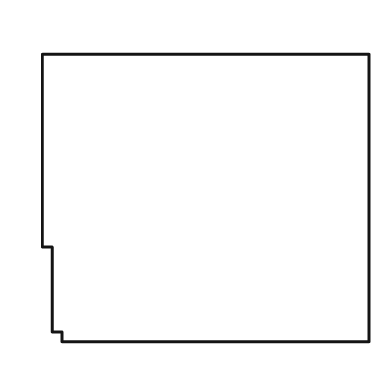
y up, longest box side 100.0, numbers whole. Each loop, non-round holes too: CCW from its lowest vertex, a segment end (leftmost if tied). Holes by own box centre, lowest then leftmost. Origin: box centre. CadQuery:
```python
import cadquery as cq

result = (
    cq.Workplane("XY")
    .moveTo(-44.0, -44.0)
    .lineTo(50.0, -44.0)
    .lineTo(50.0, 44.0)
    .lineTo(-50.0, 44.0)
    .lineTo(-50.0, -15.0)
    .lineTo(-47.0, -15.0)
    .lineTo(-47.0, -41.0)
    .lineTo(-44.0, -41.0)
    .close()
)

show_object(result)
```